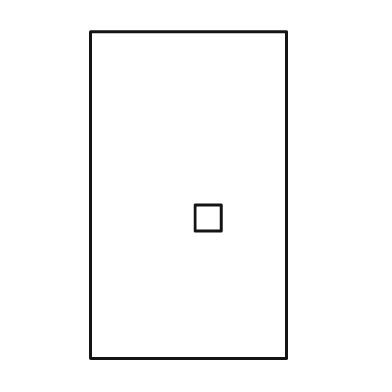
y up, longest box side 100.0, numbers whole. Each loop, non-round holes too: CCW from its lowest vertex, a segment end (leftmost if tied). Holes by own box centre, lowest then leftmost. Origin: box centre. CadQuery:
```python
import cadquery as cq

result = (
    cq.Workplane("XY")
    .moveTo(-30.0, -50.0)
    .lineTo(30.0, -50.0)
    .lineTo(30.0, 50.0)
    .lineTo(-30.0, 50.0)
    .close()
    .moveTo(2.0, -11.0)
    .lineTo(10.0, -11.0)
    .lineTo(10.0, -3.0)
    .lineTo(2.0, -3.0)
    .close()
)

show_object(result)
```